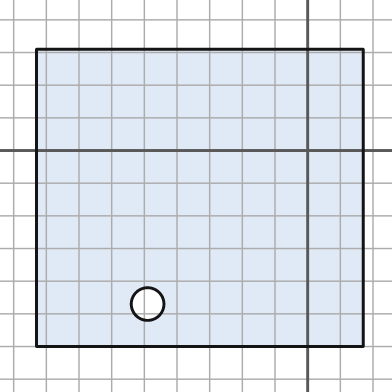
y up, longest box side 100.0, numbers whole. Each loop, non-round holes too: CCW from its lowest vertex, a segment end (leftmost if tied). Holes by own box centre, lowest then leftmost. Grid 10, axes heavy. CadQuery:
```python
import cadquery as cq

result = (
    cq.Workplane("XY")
    .moveTo(-83.0, -60.0)
    .lineTo(17.0, -60.0)
    .lineTo(17.0, 31.0)
    .lineTo(-83.0, 31.0)
    .close()
    .moveTo(-49.0, -47.0)
    .circle(5.0)
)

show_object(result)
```